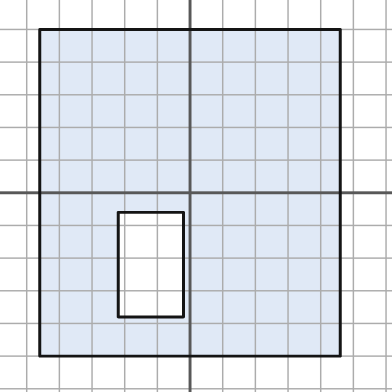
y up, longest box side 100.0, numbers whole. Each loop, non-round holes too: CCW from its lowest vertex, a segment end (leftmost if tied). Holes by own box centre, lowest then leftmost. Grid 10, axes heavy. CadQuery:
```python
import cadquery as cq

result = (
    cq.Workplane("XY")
    .moveTo(-46.0, -50.0)
    .lineTo(46.0, -50.0)
    .lineTo(46.0, 50.0)
    .lineTo(-46.0, 50.0)
    .close()
    .moveTo(-22.0, -38.0)
    .lineTo(-2.0, -38.0)
    .lineTo(-2.0, -6.0)
    .lineTo(-22.0, -6.0)
    .close()
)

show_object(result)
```